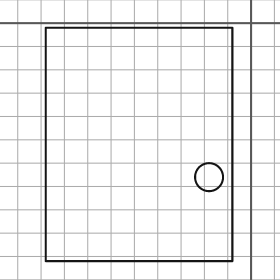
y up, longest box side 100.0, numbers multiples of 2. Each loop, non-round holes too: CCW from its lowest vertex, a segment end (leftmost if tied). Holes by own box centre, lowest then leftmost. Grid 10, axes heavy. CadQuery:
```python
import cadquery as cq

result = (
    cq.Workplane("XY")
    .moveTo(-88.0, -102.0)
    .lineTo(-8.0, -102.0)
    .lineTo(-8.0, -2.0)
    .lineTo(-88.0, -2.0)
    .close()
    .moveTo(-18.0, -66.0)
    .circle(6.0)
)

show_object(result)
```